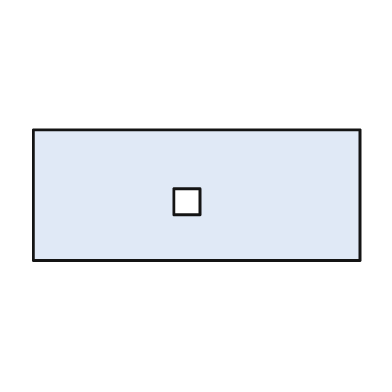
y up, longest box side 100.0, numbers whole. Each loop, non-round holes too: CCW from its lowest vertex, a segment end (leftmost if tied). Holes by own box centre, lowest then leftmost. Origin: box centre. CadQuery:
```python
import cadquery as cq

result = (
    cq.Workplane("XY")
    .moveTo(-50.0, -20.0)
    .lineTo(50.0, -20.0)
    .lineTo(50.0, 20.0)
    .lineTo(-50.0, 20.0)
    .close()
    .moveTo(-7.0, -6.0)
    .lineTo(1.0, -6.0)
    .lineTo(1.0, 2.0)
    .lineTo(-7.0, 2.0)
    .close()
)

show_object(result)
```